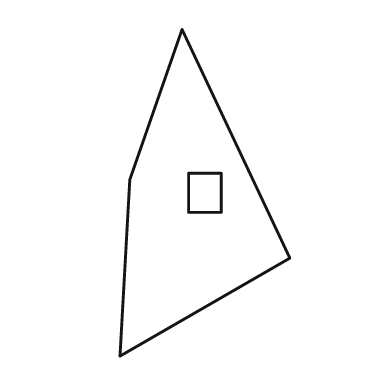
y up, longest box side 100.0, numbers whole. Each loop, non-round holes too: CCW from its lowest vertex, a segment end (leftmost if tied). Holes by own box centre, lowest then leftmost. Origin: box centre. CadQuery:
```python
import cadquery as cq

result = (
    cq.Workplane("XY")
    .moveTo(-26.0, -50.0)
    .lineTo(26.0, -20.0)
    .lineTo(-7.0, 50.0)
    .lineTo(-23.0, 4.0)
    .close()
    .moveTo(-5.0, -6.0)
    .lineTo(5.0, -6.0)
    .lineTo(5.0, 6.0)
    .lineTo(-5.0, 6.0)
    .close()
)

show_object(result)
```